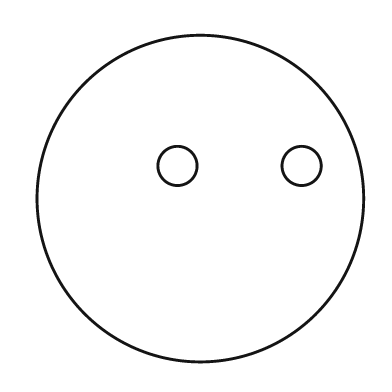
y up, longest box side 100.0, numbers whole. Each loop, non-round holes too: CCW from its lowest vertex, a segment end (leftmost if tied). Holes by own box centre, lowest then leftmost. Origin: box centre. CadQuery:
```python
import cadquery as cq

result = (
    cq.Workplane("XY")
    .moveTo(0.0, 0.0)
    .circle(50.0)
    .moveTo(-7.0, 10.0)
    .circle(6.0)
    .moveTo(31.0, 10.0)
    .circle(6.0)
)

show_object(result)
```